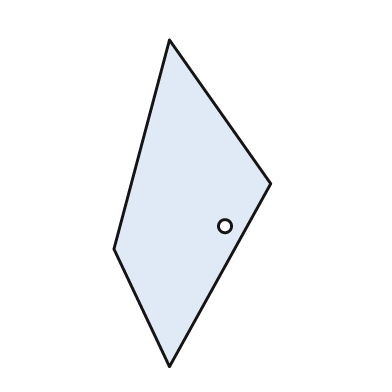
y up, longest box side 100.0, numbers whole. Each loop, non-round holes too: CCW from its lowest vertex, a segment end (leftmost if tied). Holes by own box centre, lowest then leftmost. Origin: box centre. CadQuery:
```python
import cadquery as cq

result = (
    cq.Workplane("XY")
    .moveTo(-7.0, -50.0)
    .lineTo(24.0, 6.0)
    .lineTo(-7.0, 50.0)
    .lineTo(-24.0, -14.0)
    .close()
    .moveTo(10.0, -7.0)
    .circle(2.0)
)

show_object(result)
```